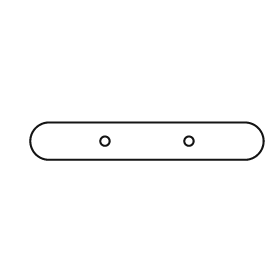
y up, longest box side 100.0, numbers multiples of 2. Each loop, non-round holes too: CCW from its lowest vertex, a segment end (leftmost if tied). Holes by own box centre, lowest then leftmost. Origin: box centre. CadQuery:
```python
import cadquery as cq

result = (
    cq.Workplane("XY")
    .moveTo(-42.0, -8.0)
    .lineTo(42.0, -8.0)
    .threePointArc((50.0, 0.0), (42.0, 8.0))
    .lineTo(-42.0, 8.0)
    .threePointArc((-50.0, 0.0), (-42.0, -8.0))
    .close()
    .moveTo(-18.0, 0.0)
    .circle(2.0)
    .moveTo(18.0, 0.0)
    .circle(2.0)
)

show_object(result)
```